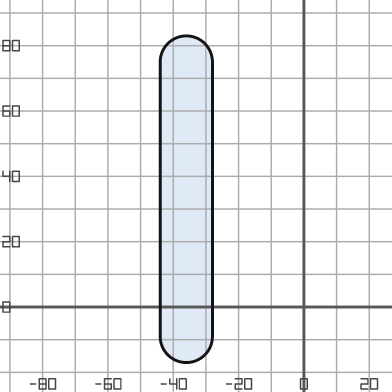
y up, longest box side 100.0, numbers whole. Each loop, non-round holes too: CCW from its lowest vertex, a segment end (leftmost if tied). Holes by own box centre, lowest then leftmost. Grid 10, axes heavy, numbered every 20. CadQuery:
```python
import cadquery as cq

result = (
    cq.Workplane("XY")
    .moveTo(-44.0, -9.0)
    .threePointArc((-36.0, -17.0), (-28.0, -9.0))
    .lineTo(-28.0, 75.0)
    .threePointArc((-36.0, 83.0), (-44.0, 75.0))
    .close()
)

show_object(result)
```